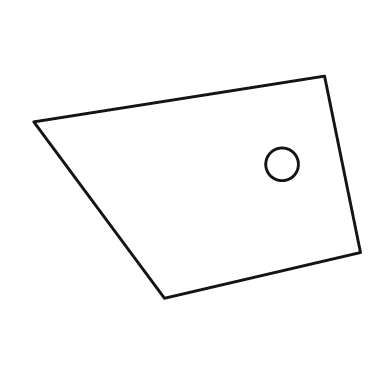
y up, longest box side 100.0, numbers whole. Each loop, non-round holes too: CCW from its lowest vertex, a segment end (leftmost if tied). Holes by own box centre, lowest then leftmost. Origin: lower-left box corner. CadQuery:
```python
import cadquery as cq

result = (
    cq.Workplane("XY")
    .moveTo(40.0, 0.0)
    .lineTo(100.0, 14.0)
    .lineTo(89.0, 68.0)
    .lineTo(0.0, 54.0)
    .close()
    .moveTo(76.0, 41.0)
    .circle(5.0)
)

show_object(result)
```